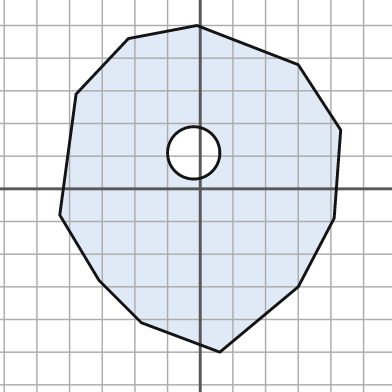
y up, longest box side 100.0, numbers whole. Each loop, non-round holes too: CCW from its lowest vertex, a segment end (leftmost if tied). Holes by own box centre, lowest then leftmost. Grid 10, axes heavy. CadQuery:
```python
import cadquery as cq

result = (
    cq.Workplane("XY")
    .moveTo(6.0, -50.0)
    .lineTo(30.0, -30.0)
    .lineTo(41.0, -9.0)
    .lineTo(43.0, 18.0)
    .lineTo(30.0, 38.0)
    .lineTo(-1.0, 50.0)
    .lineTo(-22.0, 46.0)
    .lineTo(-38.0, 29.0)
    .lineTo(-43.0, -8.0)
    .lineTo(-31.0, -28.0)
    .lineTo(-18.0, -41.0)
    .close()
    .moveTo(-2.0, 11.0)
    .circle(8.0)
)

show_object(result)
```